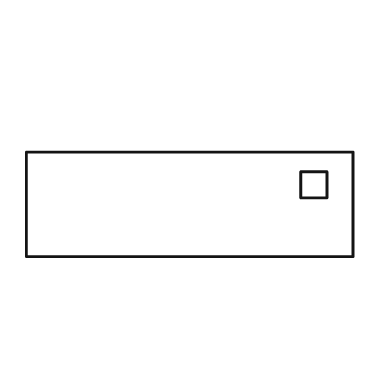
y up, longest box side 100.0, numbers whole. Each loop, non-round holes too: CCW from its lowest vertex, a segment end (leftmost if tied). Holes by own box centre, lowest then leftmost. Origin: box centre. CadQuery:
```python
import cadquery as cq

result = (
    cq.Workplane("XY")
    .moveTo(-50.0, -16.0)
    .lineTo(50.0, -16.0)
    .lineTo(50.0, 16.0)
    .lineTo(-50.0, 16.0)
    .close()
    .moveTo(34.0, 2.0)
    .lineTo(42.0, 2.0)
    .lineTo(42.0, 10.0)
    .lineTo(34.0, 10.0)
    .close()
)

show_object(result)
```